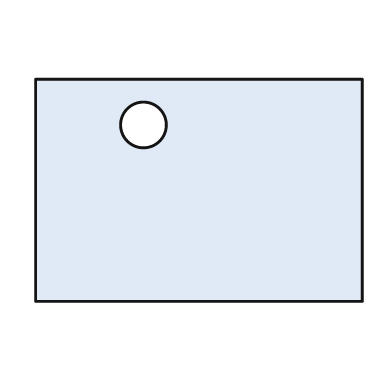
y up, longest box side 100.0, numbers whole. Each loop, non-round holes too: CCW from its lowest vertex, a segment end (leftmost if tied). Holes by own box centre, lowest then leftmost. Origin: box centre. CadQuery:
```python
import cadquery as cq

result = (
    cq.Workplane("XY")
    .moveTo(-50.0, -34.0)
    .lineTo(50.0, -34.0)
    .lineTo(50.0, 34.0)
    .lineTo(-50.0, 34.0)
    .close()
    .moveTo(-17.0, 20.0)
    .circle(7.0)
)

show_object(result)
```